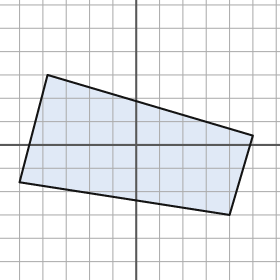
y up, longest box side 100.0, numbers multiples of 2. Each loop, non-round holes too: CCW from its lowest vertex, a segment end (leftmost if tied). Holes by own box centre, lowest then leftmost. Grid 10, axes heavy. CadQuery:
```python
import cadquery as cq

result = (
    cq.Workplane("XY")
    .moveTo(40.0, -30.0)
    .lineTo(50.0, 4.0)
    .lineTo(-38.0, 30.0)
    .lineTo(-50.0, -16.0)
    .close()
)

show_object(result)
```